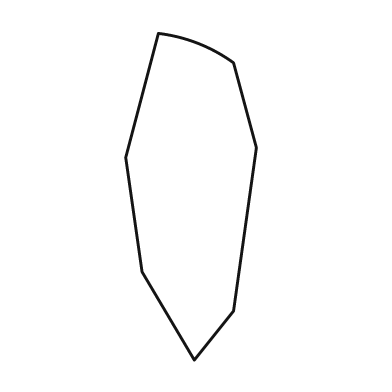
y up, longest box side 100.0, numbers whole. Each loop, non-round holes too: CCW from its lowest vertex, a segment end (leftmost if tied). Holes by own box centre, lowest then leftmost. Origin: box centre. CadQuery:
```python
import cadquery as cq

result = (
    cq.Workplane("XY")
    .moveTo(1.0, -50.0)
    .lineTo(13.0, -35.0)
    .lineTo(20.0, 15.0)
    .lineTo(13.0, 41.0)
    .threePointArc((2.0, 47.0), (-10.0, 50.0))
    .lineTo(-20.0, 12.0)
    .lineTo(-15.0, -23.0)
    .close()
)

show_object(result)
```